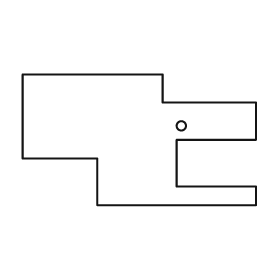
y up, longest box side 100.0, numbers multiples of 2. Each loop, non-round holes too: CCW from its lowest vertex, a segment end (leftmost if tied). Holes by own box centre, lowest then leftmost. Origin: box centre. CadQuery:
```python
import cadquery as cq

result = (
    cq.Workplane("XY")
    .moveTo(-18.0, -28.0)
    .lineTo(50.0, -28.0)
    .lineTo(50.0, -20.0)
    .lineTo(16.0, -20.0)
    .lineTo(16.0, 0.0)
    .lineTo(50.0, 0.0)
    .lineTo(50.0, 16.0)
    .lineTo(10.0, 16.0)
    .lineTo(10.0, 28.0)
    .lineTo(-50.0, 28.0)
    .lineTo(-50.0, -8.0)
    .lineTo(-18.0, -8.0)
    .close()
    .moveTo(18.0, 6.0)
    .circle(2.0)
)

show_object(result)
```